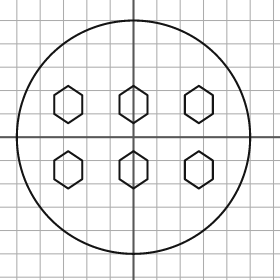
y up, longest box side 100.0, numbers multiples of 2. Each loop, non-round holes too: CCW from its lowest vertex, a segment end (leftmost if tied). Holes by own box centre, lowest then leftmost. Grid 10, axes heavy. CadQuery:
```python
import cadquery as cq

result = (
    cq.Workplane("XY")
    .moveTo(0.0, 0.0)
    .circle(50.0)
    .moveTo(-28.0, -22.0)
    .lineTo(-22.0, -18.0)
    .lineTo(-22.0, -10.0)
    .lineTo(-28.0, -6.0)
    .lineTo(-34.0, -10.0)
    .lineTo(-34.0, -18.0)
    .close()
    .moveTo(0.0, -22.0)
    .lineTo(6.0, -18.0)
    .lineTo(6.0, -10.0)
    .lineTo(0.0, -6.0)
    .lineTo(-6.0, -10.0)
    .lineTo(-6.0, -18.0)
    .close()
    .moveTo(28.0, -22.0)
    .lineTo(34.0, -18.0)
    .lineTo(34.0, -10.0)
    .lineTo(28.0, -6.0)
    .lineTo(22.0, -10.0)
    .lineTo(22.0, -18.0)
    .close()
    .moveTo(-28.0, 6.0)
    .lineTo(-22.0, 10.0)
    .lineTo(-22.0, 18.0)
    .lineTo(-28.0, 22.0)
    .lineTo(-34.0, 18.0)
    .lineTo(-34.0, 10.0)
    .close()
    .moveTo(0.0, 6.0)
    .lineTo(6.0, 10.0)
    .lineTo(6.0, 18.0)
    .lineTo(0.0, 22.0)
    .lineTo(-6.0, 18.0)
    .lineTo(-6.0, 10.0)
    .close()
    .moveTo(28.0, 6.0)
    .lineTo(34.0, 10.0)
    .lineTo(34.0, 18.0)
    .lineTo(28.0, 22.0)
    .lineTo(22.0, 18.0)
    .lineTo(22.0, 10.0)
    .close()
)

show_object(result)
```